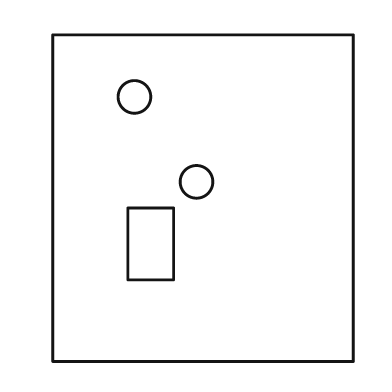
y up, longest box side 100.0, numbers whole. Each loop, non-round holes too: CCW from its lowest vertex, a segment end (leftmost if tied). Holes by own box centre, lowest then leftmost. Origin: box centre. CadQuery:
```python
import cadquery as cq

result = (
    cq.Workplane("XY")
    .moveTo(-46.0, -50.0)
    .lineTo(46.0, -50.0)
    .lineTo(46.0, 50.0)
    .lineTo(-46.0, 50.0)
    .close()
    .moveTo(-23.0, -25.0)
    .lineTo(-9.0, -25.0)
    .lineTo(-9.0, -3.0)
    .lineTo(-23.0, -3.0)
    .close()
    .moveTo(-2.0, 5.0)
    .circle(5.0)
    .moveTo(-21.0, 31.0)
    .circle(5.0)
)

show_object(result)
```